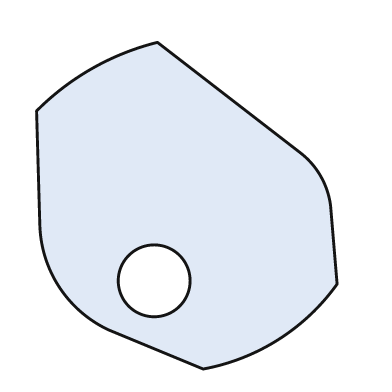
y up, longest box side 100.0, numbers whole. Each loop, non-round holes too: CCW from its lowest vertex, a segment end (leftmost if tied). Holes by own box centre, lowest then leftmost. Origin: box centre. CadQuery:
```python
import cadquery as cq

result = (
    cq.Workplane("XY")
    .moveTo(5.0, -50.0)
    .threePointArc((28.0, -41.0), (46.0, -24.0))
    .lineTo(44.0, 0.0)
    .threePointArc((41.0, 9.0), (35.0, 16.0))
    .lineTo(-9.0, 50.0)
    .threePointArc((-29.0, 42.0), (-46.0, 29.0))
    .lineTo(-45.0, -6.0)
    .threePointArc((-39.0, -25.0), (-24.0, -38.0))
    .close()
    .moveTo(-10.0, -23.0)
    .circle(11.0)
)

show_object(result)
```